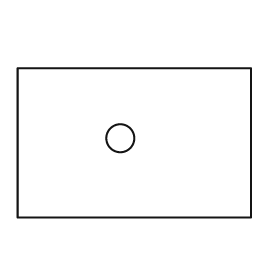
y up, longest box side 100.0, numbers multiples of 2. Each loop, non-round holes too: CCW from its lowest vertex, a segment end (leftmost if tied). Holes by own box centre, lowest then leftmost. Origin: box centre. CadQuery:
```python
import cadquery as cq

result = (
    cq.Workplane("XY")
    .moveTo(-50.0, -32.0)
    .lineTo(50.0, -32.0)
    .lineTo(50.0, 32.0)
    .lineTo(-50.0, 32.0)
    .close()
    .moveTo(-6.0, 2.0)
    .circle(6.0)
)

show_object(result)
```